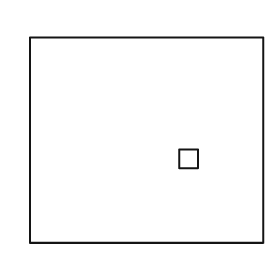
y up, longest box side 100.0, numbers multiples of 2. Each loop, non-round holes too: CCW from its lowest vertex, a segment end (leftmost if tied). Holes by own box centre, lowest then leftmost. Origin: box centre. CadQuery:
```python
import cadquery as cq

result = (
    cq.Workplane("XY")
    .moveTo(-50.0, -44.0)
    .lineTo(50.0, -44.0)
    .lineTo(50.0, 44.0)
    .lineTo(-50.0, 44.0)
    .close()
    .moveTo(14.0, -12.0)
    .lineTo(22.0, -12.0)
    .lineTo(22.0, -4.0)
    .lineTo(14.0, -4.0)
    .close()
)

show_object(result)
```